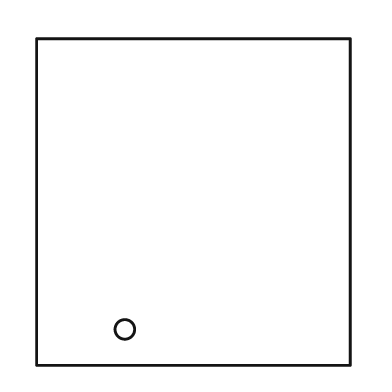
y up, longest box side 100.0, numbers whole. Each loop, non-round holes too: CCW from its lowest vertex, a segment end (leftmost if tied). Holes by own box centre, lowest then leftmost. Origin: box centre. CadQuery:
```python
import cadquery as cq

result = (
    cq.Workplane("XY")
    .moveTo(-48.0, -50.0)
    .lineTo(48.0, -50.0)
    .lineTo(48.0, 50.0)
    .lineTo(-48.0, 50.0)
    .close()
    .moveTo(-21.0, -39.0)
    .circle(3.0)
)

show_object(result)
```